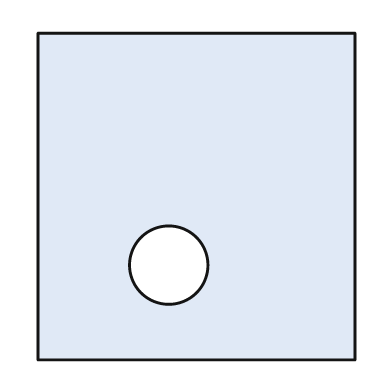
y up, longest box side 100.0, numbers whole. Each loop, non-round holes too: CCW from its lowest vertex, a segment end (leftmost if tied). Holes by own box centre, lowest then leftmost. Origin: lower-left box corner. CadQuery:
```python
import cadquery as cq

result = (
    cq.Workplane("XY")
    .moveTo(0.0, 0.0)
    .lineTo(97.0, 0.0)
    .lineTo(97.0, 100.0)
    .lineTo(0.0, 100.0)
    .close()
    .moveTo(40.0, 29.0)
    .circle(12.0)
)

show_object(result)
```